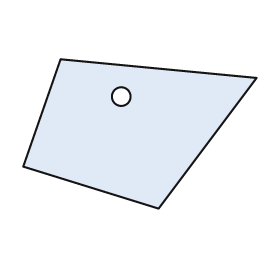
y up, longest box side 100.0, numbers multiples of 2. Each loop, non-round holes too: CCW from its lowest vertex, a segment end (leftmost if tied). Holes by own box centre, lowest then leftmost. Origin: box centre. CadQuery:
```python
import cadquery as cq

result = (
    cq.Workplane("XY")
    .moveTo(8.0, -32.0)
    .lineTo(50.0, 24.0)
    .lineTo(-34.0, 32.0)
    .lineTo(-50.0, -14.0)
    .close()
    .moveTo(-8.0, 16.0)
    .circle(4.0)
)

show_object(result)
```